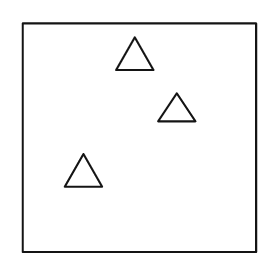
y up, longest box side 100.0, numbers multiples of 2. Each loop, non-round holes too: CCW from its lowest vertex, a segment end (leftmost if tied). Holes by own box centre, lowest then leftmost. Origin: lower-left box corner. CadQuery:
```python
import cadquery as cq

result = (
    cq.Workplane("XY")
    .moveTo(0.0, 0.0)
    .lineTo(100.0, 0.0)
    .lineTo(100.0, 98.0)
    .lineTo(0.0, 98.0)
    .close()
    .moveTo(18.0, 28.0)
    .lineTo(34.0, 28.0)
    .lineTo(26.0, 42.0)
    .close()
    .moveTo(58.0, 56.0)
    .lineTo(74.0, 56.0)
    .lineTo(66.0, 68.0)
    .close()
    .moveTo(40.0, 78.0)
    .lineTo(56.0, 78.0)
    .lineTo(48.0, 92.0)
    .close()
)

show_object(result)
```